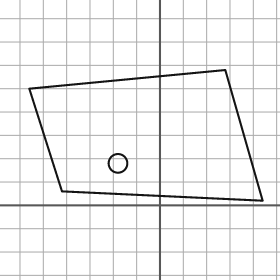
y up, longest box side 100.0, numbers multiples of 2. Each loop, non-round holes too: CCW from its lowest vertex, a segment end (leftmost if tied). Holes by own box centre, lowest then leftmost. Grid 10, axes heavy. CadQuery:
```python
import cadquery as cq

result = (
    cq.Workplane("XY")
    .moveTo(44.0, 2.0)
    .lineTo(28.0, 58.0)
    .lineTo(-56.0, 50.0)
    .lineTo(-42.0, 6.0)
    .close()
    .moveTo(-18.0, 18.0)
    .circle(4.0)
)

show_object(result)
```